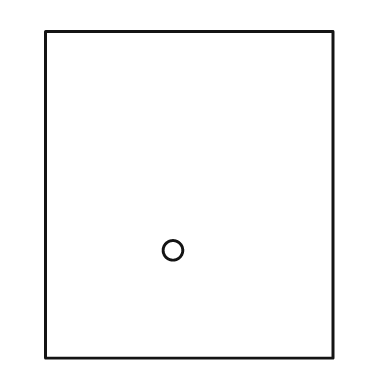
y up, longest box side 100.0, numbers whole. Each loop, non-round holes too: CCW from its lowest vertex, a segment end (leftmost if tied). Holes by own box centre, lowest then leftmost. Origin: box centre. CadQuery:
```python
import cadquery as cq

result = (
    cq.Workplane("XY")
    .moveTo(-44.0, -50.0)
    .lineTo(44.0, -50.0)
    .lineTo(44.0, 50.0)
    .lineTo(-44.0, 50.0)
    .close()
    .moveTo(-5.0, -17.0)
    .circle(3.0)
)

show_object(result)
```